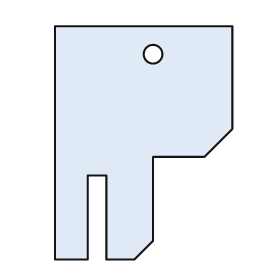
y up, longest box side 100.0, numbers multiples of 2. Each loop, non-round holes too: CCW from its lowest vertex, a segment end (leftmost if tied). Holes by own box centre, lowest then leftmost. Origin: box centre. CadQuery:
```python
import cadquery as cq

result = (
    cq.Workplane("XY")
    .moveTo(-38.0, -50.0)
    .lineTo(-24.0, -50.0)
    .lineTo(-24.0, -14.0)
    .lineTo(-16.0, -14.0)
    .lineTo(-16.0, -50.0)
    .lineTo(-4.0, -50.0)
    .lineTo(4.0, -42.0)
    .lineTo(4.0, -6.0)
    .lineTo(26.0, -6.0)
    .lineTo(38.0, 6.0)
    .lineTo(38.0, 50.0)
    .lineTo(-38.0, 50.0)
    .close()
    .moveTo(4.0, 38.0)
    .circle(4.0)
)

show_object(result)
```